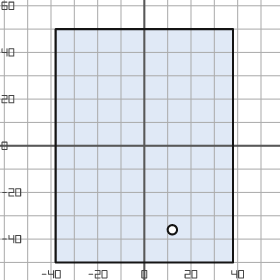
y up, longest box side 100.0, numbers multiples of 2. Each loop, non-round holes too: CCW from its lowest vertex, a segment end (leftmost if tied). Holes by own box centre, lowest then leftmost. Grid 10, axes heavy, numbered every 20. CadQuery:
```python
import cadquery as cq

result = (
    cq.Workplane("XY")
    .moveTo(-38.0, -50.0)
    .lineTo(38.0, -50.0)
    .lineTo(38.0, 50.0)
    .lineTo(-38.0, 50.0)
    .close()
    .moveTo(12.0, -36.0)
    .circle(2.0)
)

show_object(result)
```